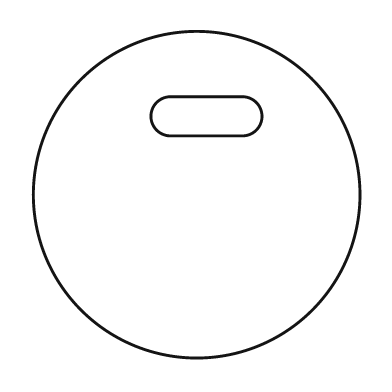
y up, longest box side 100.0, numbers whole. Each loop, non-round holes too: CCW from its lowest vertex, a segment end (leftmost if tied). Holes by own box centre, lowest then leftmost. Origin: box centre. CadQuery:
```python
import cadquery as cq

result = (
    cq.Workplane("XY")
    .moveTo(0.0, 0.0)
    .circle(50.0)
    .moveTo(-8.0, 18.0)
    .lineTo(14.0, 18.0)
    .threePointArc((20.0, 24.0), (14.0, 30.0))
    .lineTo(-8.0, 30.0)
    .threePointArc((-14.0, 24.0), (-8.0, 18.0))
    .close()
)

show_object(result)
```